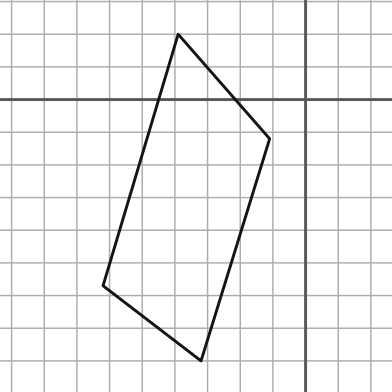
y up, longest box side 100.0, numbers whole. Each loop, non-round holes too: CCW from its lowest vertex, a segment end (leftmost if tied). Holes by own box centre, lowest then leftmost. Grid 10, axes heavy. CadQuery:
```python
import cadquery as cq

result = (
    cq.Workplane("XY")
    .moveTo(-32.0, -80.0)
    .lineTo(-11.0, -12.0)
    .lineTo(-39.0, 20.0)
    .lineTo(-62.0, -57.0)
    .close()
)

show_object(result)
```